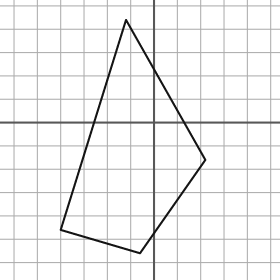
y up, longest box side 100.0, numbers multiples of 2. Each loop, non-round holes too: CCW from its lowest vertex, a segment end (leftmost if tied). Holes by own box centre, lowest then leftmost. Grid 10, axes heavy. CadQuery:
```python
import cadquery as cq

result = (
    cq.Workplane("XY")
    .moveTo(-6.0, -56.0)
    .lineTo(22.0, -16.0)
    .lineTo(-12.0, 44.0)
    .lineTo(-40.0, -46.0)
    .close()
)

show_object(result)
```